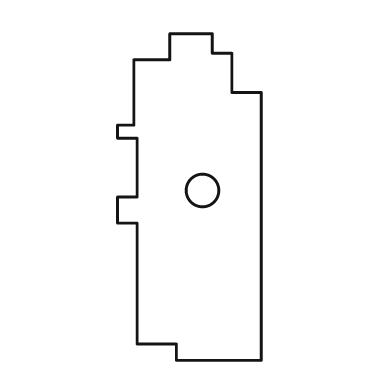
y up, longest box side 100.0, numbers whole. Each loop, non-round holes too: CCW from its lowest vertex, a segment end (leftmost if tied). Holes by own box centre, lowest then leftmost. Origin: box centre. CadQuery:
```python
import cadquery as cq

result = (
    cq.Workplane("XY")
    .moveTo(-4.0, -50.0)
    .lineTo(22.0, -50.0)
    .lineTo(22.0, 32.0)
    .lineTo(13.0, 32.0)
    .lineTo(13.0, 44.0)
    .lineTo(7.0, 44.0)
    .lineTo(7.0, 50.0)
    .lineTo(-6.0, 50.0)
    .lineTo(-6.0, 42.0)
    .lineTo(-17.0, 42.0)
    .lineTo(-17.0, 22.0)
    .lineTo(-22.0, 22.0)
    .lineTo(-22.0, 18.0)
    .lineTo(-16.0, 18.0)
    .lineTo(-16.0, 0.0)
    .lineTo(-22.0, 0.0)
    .lineTo(-22.0, -8.0)
    .lineTo(-16.0, -8.0)
    .lineTo(-16.0, -45.0)
    .lineTo(-4.0, -45.0)
    .close()
    .moveTo(4.0, 2.0)
    .circle(5.0)
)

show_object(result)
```